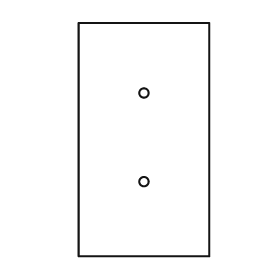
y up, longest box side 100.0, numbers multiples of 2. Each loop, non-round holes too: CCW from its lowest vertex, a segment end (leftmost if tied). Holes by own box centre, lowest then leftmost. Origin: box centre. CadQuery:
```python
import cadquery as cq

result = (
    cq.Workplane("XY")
    .moveTo(-28.0, -50.0)
    .lineTo(28.0, -50.0)
    .lineTo(28.0, 50.0)
    .lineTo(-28.0, 50.0)
    .close()
    .moveTo(0.0, -18.0)
    .circle(2.0)
    .moveTo(0.0, 20.0)
    .circle(2.0)
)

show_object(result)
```